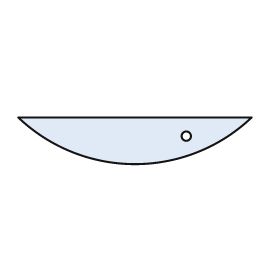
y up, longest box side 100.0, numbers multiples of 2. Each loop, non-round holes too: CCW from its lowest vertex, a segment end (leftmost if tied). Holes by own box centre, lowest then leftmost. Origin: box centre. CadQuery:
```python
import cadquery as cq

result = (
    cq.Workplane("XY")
    .moveTo(-50.0, 10.0)
    .threePointArc((0.0, -10.0), (50.0, 10.0))
    .close()
    .moveTo(22.0, 2.0)
    .circle(2.0)
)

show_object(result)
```